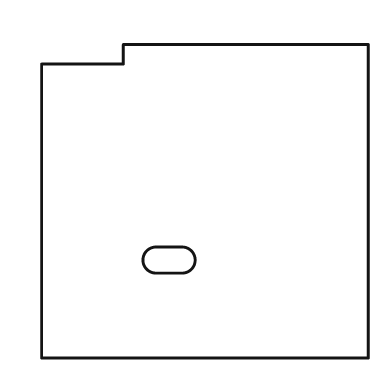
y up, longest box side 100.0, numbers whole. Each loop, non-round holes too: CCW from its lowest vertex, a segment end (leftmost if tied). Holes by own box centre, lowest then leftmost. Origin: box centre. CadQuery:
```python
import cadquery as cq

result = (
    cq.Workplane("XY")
    .moveTo(-50.0, -48.0)
    .lineTo(50.0, -48.0)
    .lineTo(50.0, 48.0)
    .lineTo(-25.0, 48.0)
    .lineTo(-25.0, 42.0)
    .lineTo(-50.0, 42.0)
    .close()
    .moveTo(-15.0, -22.0)
    .lineTo(-7.0, -22.0)
    .threePointArc((-3.0, -18.0), (-7.0, -14.0))
    .lineTo(-15.0, -14.0)
    .threePointArc((-19.0, -18.0), (-15.0, -22.0))
    .close()
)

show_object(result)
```